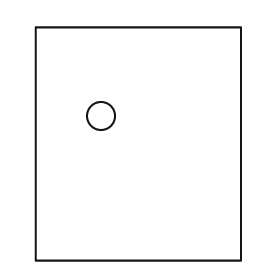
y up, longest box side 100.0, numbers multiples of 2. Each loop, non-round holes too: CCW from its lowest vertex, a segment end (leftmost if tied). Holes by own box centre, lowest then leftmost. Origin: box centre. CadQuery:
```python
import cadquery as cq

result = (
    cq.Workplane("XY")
    .moveTo(-44.0, -50.0)
    .lineTo(44.0, -50.0)
    .lineTo(44.0, 50.0)
    .lineTo(-44.0, 50.0)
    .close()
    .moveTo(-16.0, 12.0)
    .circle(6.0)
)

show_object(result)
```